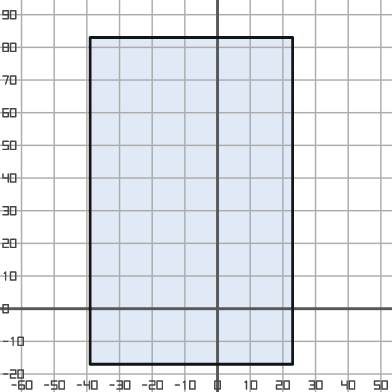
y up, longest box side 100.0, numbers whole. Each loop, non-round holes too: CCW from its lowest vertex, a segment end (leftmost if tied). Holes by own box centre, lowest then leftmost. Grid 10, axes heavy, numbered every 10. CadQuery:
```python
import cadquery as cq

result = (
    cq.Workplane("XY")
    .moveTo(-39.0, -17.0)
    .lineTo(23.0, -17.0)
    .lineTo(23.0, 83.0)
    .lineTo(-39.0, 83.0)
    .close()
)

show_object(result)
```